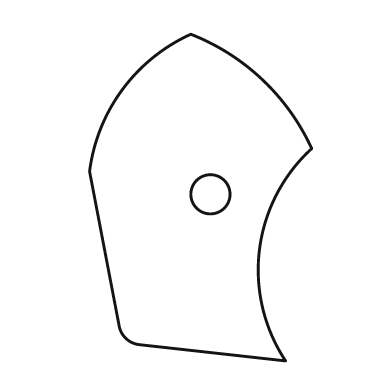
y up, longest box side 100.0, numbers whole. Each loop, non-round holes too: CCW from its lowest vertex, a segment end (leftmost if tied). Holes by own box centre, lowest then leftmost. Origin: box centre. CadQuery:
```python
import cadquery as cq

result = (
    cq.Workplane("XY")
    .moveTo(26.0, -50.0)
    .threePointArc((18.0, -16.0), (34.0, 15.0))
    .threePointArc((19.0, 36.0), (-3.0, 50.0))
    .threePointArc((-24.0, 33.0), (-34.0, 8.0))
    .lineTo(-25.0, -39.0)
    .threePointArc((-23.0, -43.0), (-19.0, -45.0))
    .close()
    .moveTo(3.0, 1.0)
    .circle(6.0)
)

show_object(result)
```